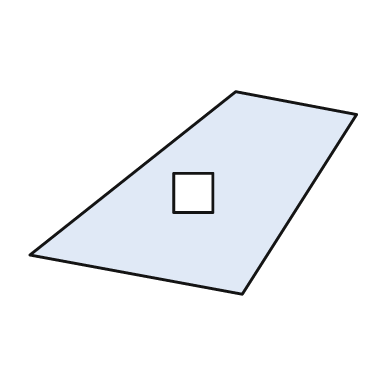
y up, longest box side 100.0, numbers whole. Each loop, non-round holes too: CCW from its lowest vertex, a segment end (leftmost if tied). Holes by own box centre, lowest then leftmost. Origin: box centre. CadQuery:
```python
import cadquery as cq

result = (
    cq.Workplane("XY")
    .moveTo(15.0, -31.0)
    .lineTo(50.0, 24.0)
    .lineTo(13.0, 31.0)
    .lineTo(-50.0, -19.0)
    .close()
    .moveTo(-6.0, -6.0)
    .lineTo(6.0, -6.0)
    .lineTo(6.0, 6.0)
    .lineTo(-6.0, 6.0)
    .close()
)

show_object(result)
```